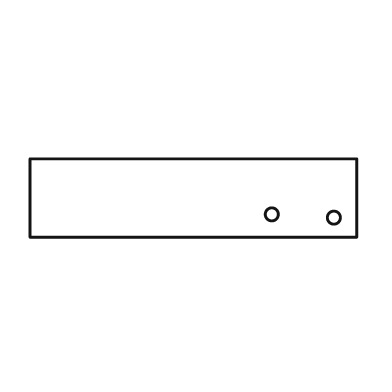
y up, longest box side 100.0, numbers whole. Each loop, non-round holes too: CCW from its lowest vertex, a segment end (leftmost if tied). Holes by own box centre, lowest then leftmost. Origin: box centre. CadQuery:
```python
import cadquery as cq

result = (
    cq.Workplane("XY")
    .moveTo(-50.0, -12.0)
    .lineTo(50.0, -12.0)
    .lineTo(50.0, 12.0)
    .lineTo(-50.0, 12.0)
    .close()
    .moveTo(43.0, -6.0)
    .circle(2.0)
    .moveTo(24.0, -5.0)
    .circle(2.0)
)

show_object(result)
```